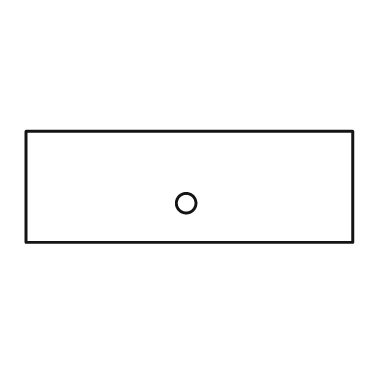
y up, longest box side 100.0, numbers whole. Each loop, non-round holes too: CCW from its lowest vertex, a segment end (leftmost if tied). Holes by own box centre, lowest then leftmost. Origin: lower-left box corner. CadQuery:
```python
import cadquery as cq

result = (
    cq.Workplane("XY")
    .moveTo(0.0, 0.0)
    .lineTo(100.0, 0.0)
    .lineTo(100.0, 34.0)
    .lineTo(0.0, 34.0)
    .close()
    .moveTo(49.0, 12.0)
    .circle(3.0)
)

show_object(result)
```